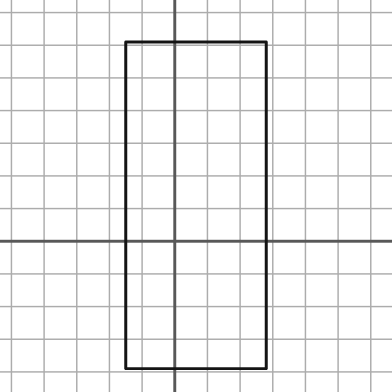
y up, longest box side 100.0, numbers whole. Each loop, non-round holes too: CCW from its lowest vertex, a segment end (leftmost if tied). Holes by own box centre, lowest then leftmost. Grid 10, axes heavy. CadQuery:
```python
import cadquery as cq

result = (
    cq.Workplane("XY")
    .moveTo(-15.0, -39.0)
    .lineTo(28.0, -39.0)
    .lineTo(28.0, 61.0)
    .lineTo(-15.0, 61.0)
    .close()
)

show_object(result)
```